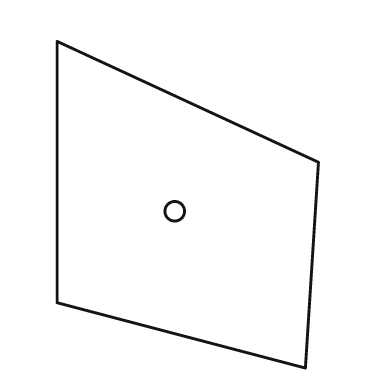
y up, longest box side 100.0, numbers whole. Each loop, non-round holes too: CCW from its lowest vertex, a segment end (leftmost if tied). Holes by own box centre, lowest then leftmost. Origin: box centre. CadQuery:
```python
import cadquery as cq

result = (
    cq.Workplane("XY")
    .moveTo(36.0, -50.0)
    .lineTo(40.0, 13.0)
    .lineTo(-40.0, 50.0)
    .lineTo(-40.0, -30.0)
    .close()
    .moveTo(-4.0, -2.0)
    .circle(3.0)
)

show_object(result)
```